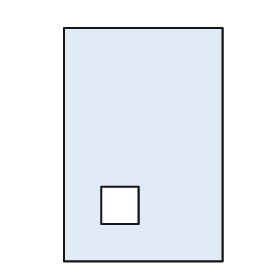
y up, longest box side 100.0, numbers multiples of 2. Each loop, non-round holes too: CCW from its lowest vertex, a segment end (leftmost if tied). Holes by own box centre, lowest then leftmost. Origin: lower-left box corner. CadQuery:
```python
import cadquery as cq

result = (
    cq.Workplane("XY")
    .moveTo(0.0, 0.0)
    .lineTo(68.0, 0.0)
    .lineTo(68.0, 100.0)
    .lineTo(0.0, 100.0)
    .close()
    .moveTo(16.0, 16.0)
    .lineTo(32.0, 16.0)
    .lineTo(32.0, 32.0)
    .lineTo(16.0, 32.0)
    .close()
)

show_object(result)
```